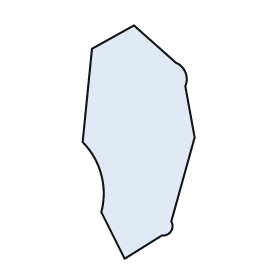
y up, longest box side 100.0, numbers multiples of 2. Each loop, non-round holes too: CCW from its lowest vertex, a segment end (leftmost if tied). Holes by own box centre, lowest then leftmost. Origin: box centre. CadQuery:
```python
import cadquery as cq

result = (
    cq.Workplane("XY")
    .moveTo(-6.0, -50.0)
    .lineTo(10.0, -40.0)
    .threePointArc((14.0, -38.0), (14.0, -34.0))
    .lineTo(24.0, 2.0)
    .lineTo(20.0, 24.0)
    .threePointArc((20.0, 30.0), (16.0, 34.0))
    .lineTo(-2.0, 50.0)
    .lineTo(-20.0, 40.0)
    .lineTo(-24.0, 0.0)
    .threePointArc((-16.0, -14.0), (-16.0, -30.0))
    .close()
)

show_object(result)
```